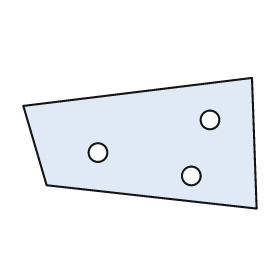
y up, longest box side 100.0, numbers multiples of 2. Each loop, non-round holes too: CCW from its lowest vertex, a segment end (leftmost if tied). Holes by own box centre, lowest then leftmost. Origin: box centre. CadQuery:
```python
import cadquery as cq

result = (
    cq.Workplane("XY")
    .moveTo(50.0, -28.0)
    .lineTo(48.0, 28.0)
    .lineTo(-50.0, 16.0)
    .lineTo(-40.0, -18.0)
    .close()
    .moveTo(22.0, -14.0)
    .circle(4.0)
    .moveTo(-18.0, -4.0)
    .circle(4.0)
    .moveTo(30.0, 10.0)
    .circle(4.0)
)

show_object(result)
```